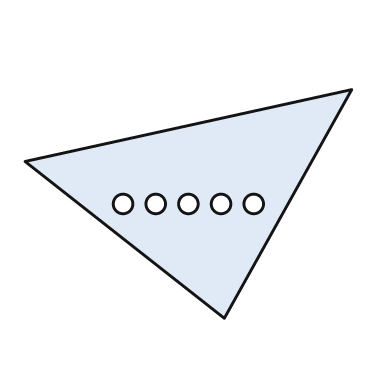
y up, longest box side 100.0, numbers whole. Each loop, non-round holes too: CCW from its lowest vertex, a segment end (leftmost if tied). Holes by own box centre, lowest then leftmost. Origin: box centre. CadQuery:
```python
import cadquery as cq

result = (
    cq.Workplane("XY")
    .moveTo(11.0, -35.0)
    .lineTo(50.0, 35.0)
    .lineTo(-50.0, 13.0)
    .close()
    .moveTo(-20.0, 0.0)
    .circle(3.0)
    .moveTo(-10.0, 0.0)
    .circle(3.0)
    .moveTo(0.0, 0.0)
    .circle(3.0)
    .moveTo(10.0, 0.0)
    .circle(3.0)
    .moveTo(20.0, 0.0)
    .circle(3.0)
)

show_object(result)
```